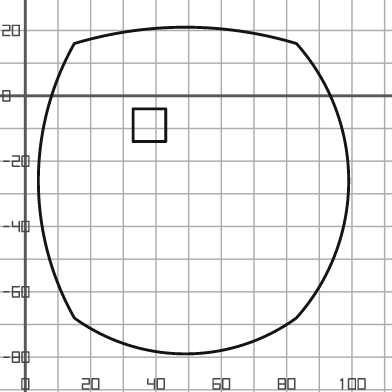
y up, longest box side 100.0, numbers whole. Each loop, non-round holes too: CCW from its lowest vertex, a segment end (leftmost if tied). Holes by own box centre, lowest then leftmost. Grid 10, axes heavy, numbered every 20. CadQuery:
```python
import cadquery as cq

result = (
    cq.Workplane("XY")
    .moveTo(15.0, -68.0)
    .threePointArc((49.0, -79.0), (83.0, -68.0))
    .threePointArc((99.0, -26.0), (83.0, 16.0))
    .threePointArc((49.0, 21.0), (15.0, 16.0))
    .threePointArc((4.0, -26.0), (15.0, -68.0))
    .close()
    .moveTo(33.0, -14.0)
    .lineTo(43.0, -14.0)
    .lineTo(43.0, -4.0)
    .lineTo(33.0, -4.0)
    .close()
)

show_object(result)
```